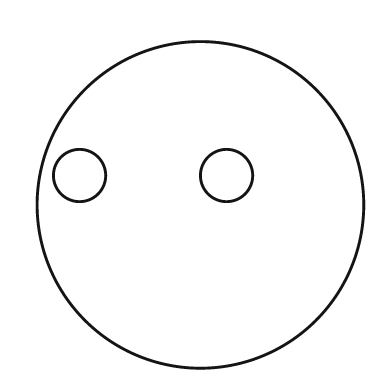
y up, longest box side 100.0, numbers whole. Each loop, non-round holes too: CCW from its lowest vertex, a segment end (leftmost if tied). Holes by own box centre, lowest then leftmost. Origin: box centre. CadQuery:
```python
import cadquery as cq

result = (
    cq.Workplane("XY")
    .moveTo(0.0, 0.0)
    .circle(50.0)
    .moveTo(-37.0, 9.0)
    .circle(8.0)
    .moveTo(8.0, 9.0)
    .circle(8.0)
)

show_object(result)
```